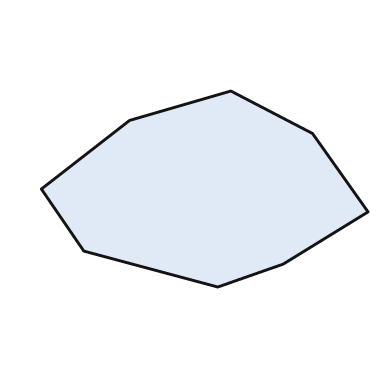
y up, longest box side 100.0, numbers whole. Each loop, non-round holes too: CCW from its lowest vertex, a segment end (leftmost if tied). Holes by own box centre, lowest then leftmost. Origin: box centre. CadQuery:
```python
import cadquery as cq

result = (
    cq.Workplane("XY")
    .moveTo(4.0, -30.0)
    .lineTo(24.0, -23.0)
    .lineTo(50.0, -7.0)
    .lineTo(33.0, 17.0)
    .lineTo(8.0, 30.0)
    .lineTo(-23.0, 21.0)
    .lineTo(-50.0, 0.0)
    .lineTo(-37.0, -19.0)
    .close()
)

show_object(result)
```